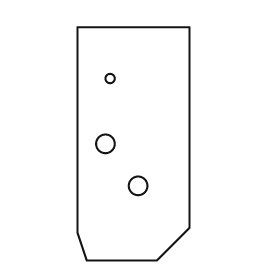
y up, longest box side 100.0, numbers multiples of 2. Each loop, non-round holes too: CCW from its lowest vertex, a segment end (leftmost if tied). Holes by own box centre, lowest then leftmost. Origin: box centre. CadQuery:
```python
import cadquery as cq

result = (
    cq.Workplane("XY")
    .moveTo(-20.0, -50.0)
    .lineTo(10.0, -50.0)
    .lineTo(24.0, -36.0)
    .lineTo(24.0, 50.0)
    .lineTo(-24.0, 50.0)
    .lineTo(-24.0, -38.0)
    .close()
    .moveTo(2.0, -18.0)
    .circle(4.0)
    .moveTo(-12.0, 0.0)
    .circle(4.0)
    .moveTo(-10.0, 28.0)
    .circle(2.0)
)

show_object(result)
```